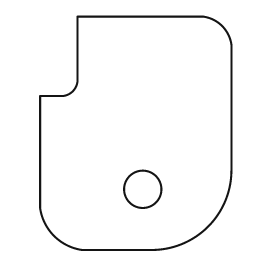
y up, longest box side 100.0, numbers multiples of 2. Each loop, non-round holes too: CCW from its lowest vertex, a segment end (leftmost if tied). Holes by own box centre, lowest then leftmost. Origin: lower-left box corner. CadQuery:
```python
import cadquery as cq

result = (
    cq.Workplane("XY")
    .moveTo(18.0, 0.0)
    .lineTo(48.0, 0.0)
    .threePointArc((72.0, 10.0), (82.0, 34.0))
    .lineTo(82.0, 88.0)
    .threePointArc((78.0, 96.0), (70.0, 100.0))
    .lineTo(16.0, 100.0)
    .lineTo(16.0, 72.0)
    .threePointArc((14.0, 68.0), (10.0, 66.0))
    .lineTo(0.0, 66.0)
    .lineTo(0.0, 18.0)
    .threePointArc((6.0, 6.0), (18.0, 0.0))
    .close()
    .moveTo(44.0, 26.0)
    .circle(8.0)
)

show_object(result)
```